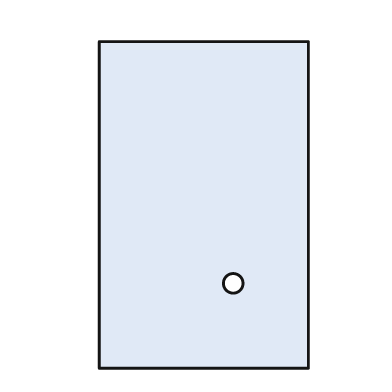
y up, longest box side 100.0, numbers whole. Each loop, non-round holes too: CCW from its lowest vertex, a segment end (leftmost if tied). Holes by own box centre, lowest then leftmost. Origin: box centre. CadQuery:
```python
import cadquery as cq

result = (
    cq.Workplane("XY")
    .moveTo(-32.0, -50.0)
    .lineTo(32.0, -50.0)
    .lineTo(32.0, 50.0)
    .lineTo(-32.0, 50.0)
    .close()
    .moveTo(9.0, -24.0)
    .circle(3.0)
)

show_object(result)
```